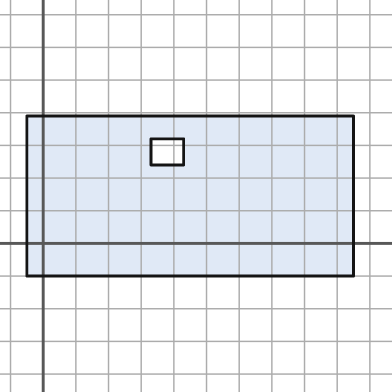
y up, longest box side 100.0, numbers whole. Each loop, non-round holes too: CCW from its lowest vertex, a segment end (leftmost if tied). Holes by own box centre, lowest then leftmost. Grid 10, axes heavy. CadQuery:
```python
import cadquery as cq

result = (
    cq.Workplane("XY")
    .moveTo(-5.0, -10.0)
    .lineTo(95.0, -10.0)
    .lineTo(95.0, 39.0)
    .lineTo(-5.0, 39.0)
    .close()
    .moveTo(33.0, 24.0)
    .lineTo(43.0, 24.0)
    .lineTo(43.0, 32.0)
    .lineTo(33.0, 32.0)
    .close()
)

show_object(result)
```